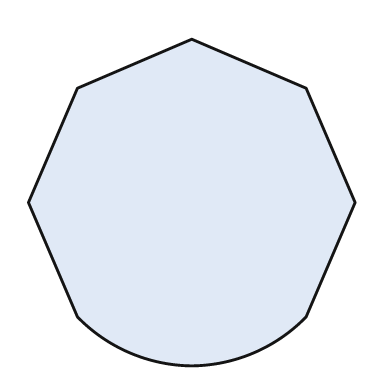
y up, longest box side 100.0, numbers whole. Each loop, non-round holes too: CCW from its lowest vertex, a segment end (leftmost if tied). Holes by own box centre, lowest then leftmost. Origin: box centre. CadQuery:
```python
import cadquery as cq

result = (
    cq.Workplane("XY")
    .moveTo(0.0, -50.0)
    .threePointArc((19.0, -46.0), (35.0, -35.0))
    .lineTo(50.0, 0.0)
    .lineTo(35.0, 35.0)
    .lineTo(0.0, 50.0)
    .lineTo(-35.0, 35.0)
    .lineTo(-50.0, 0.0)
    .lineTo(-35.0, -35.0)
    .threePointArc((-19.0, -46.0), (0.0, -50.0))
    .close()
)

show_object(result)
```